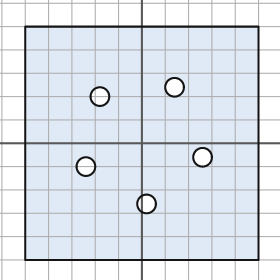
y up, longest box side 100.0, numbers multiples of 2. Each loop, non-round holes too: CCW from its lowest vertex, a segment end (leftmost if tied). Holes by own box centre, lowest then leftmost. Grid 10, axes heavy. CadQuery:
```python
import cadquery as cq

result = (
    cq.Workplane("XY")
    .moveTo(-50.0, -50.0)
    .lineTo(50.0, -50.0)
    .lineTo(50.0, 50.0)
    .lineTo(-50.0, 50.0)
    .close()
    .moveTo(2.0, -26.0)
    .circle(4.0)
    .moveTo(-24.0, -10.0)
    .circle(4.0)
    .moveTo(26.0, -6.0)
    .circle(4.0)
    .moveTo(-18.0, 20.0)
    .circle(4.0)
    .moveTo(14.0, 24.0)
    .circle(4.0)
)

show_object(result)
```